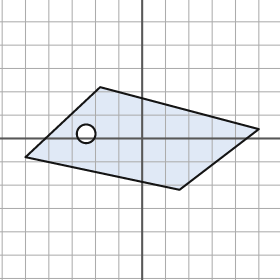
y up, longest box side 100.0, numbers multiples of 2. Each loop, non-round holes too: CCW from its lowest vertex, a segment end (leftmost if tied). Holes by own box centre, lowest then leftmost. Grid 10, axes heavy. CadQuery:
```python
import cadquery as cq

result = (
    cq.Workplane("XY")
    .moveTo(16.0, -22.0)
    .lineTo(50.0, 4.0)
    .lineTo(-18.0, 22.0)
    .lineTo(-50.0, -8.0)
    .close()
    .moveTo(-24.0, 2.0)
    .circle(4.0)
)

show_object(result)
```